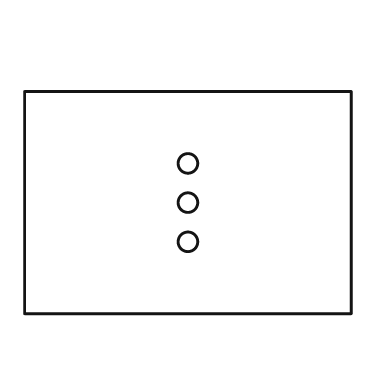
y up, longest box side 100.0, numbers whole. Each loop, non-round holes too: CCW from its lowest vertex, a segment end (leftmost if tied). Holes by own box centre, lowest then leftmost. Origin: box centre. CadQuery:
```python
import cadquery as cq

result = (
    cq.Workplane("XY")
    .moveTo(-50.0, -34.0)
    .lineTo(50.0, -34.0)
    .lineTo(50.0, 34.0)
    .lineTo(-50.0, 34.0)
    .close()
    .moveTo(0.0, -12.0)
    .circle(3.0)
    .moveTo(0.0, 0.0)
    .circle(3.0)
    .moveTo(0.0, 12.0)
    .circle(3.0)
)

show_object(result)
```